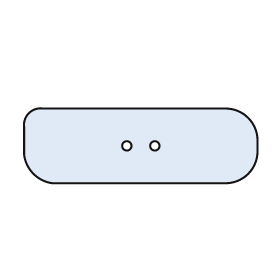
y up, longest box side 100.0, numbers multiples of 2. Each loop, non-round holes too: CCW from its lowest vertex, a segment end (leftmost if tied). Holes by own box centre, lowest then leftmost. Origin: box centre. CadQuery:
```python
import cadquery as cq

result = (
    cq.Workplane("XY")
    .moveTo(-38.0, -16.0)
    .lineTo(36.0, -16.0)
    .threePointArc((46.0, -12.0), (50.0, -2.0))
    .lineTo(50.0, 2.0)
    .threePointArc((46.0, 12.0), (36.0, 16.0))
    .lineTo(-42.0, 16.0)
    .threePointArc((-48.0, 14.0), (-50.0, 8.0))
    .lineTo(-50.0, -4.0)
    .threePointArc((-46.0, -12.0), (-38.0, -16.0))
    .close()
    .moveTo(-6.0, 0.0)
    .circle(2.0)
    .moveTo(6.0, 0.0)
    .circle(2.0)
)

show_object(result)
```